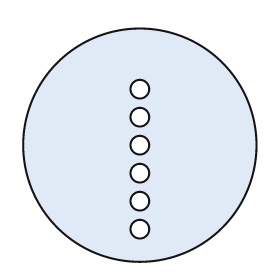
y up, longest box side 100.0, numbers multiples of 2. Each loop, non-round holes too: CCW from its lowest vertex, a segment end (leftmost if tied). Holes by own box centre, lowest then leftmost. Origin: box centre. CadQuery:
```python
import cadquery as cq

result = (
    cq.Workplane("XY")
    .moveTo(0.0, 0.0)
    .circle(50.0)
    .moveTo(0.0, -36.0)
    .circle(4.0)
    .moveTo(0.0, -24.0)
    .circle(4.0)
    .moveTo(0.0, -12.0)
    .circle(4.0)
    .moveTo(0.0, 0.0)
    .circle(4.0)
    .moveTo(0.0, 12.0)
    .circle(4.0)
    .moveTo(0.0, 24.0)
    .circle(4.0)
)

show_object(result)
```